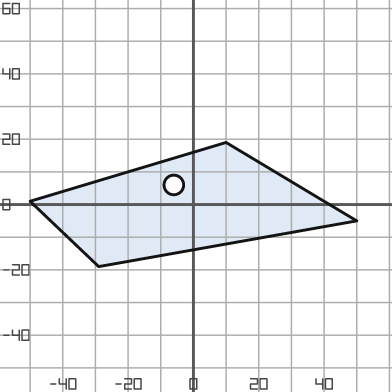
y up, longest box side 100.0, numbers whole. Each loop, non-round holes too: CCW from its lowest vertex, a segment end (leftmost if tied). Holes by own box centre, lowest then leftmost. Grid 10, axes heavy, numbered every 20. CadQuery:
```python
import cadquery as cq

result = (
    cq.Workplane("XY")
    .moveTo(-29.0, -19.0)
    .lineTo(50.0, -5.0)
    .lineTo(10.0, 19.0)
    .lineTo(-50.0, 1.0)
    .close()
    .moveTo(-6.0, 6.0)
    .circle(3.0)
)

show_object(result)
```